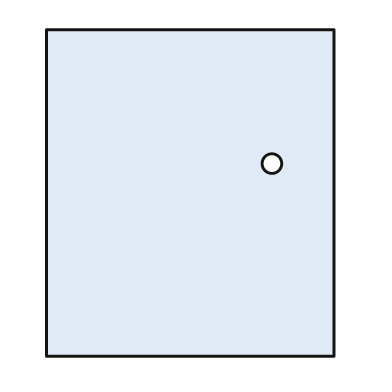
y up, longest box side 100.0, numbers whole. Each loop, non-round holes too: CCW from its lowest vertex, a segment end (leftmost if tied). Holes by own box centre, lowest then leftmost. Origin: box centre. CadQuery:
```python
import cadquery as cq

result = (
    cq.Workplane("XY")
    .moveTo(-44.0, -50.0)
    .lineTo(44.0, -50.0)
    .lineTo(44.0, 50.0)
    .lineTo(-44.0, 50.0)
    .close()
    .moveTo(25.0, 9.0)
    .circle(3.0)
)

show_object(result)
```